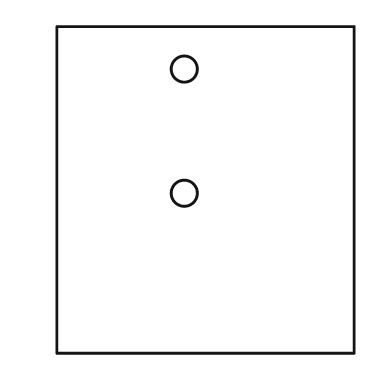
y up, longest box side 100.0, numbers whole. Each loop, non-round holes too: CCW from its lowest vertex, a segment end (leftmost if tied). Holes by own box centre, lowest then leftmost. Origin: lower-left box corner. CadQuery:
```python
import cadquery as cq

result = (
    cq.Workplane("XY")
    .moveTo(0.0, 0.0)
    .lineTo(91.0, 0.0)
    .lineTo(91.0, 100.0)
    .lineTo(0.0, 100.0)
    .close()
    .moveTo(39.0, 49.0)
    .circle(4.0)
    .moveTo(39.0, 87.0)
    .circle(4.0)
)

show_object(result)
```